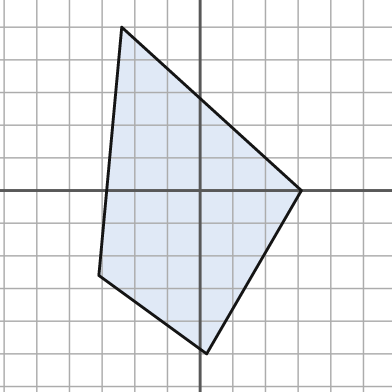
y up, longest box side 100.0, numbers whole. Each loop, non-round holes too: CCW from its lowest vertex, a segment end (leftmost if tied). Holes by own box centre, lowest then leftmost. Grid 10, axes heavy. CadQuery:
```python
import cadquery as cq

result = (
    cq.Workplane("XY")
    .moveTo(2.0, -50.0)
    .lineTo(31.0, 0.0)
    .lineTo(-24.0, 50.0)
    .lineTo(-31.0, -26.0)
    .close()
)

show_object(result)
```